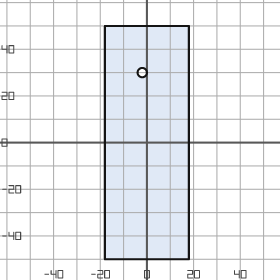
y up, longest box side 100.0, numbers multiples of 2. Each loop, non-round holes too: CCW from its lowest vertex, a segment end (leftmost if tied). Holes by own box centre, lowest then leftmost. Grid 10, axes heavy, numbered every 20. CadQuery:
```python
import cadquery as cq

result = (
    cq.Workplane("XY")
    .moveTo(-18.0, -50.0)
    .lineTo(18.0, -50.0)
    .lineTo(18.0, 50.0)
    .lineTo(-18.0, 50.0)
    .close()
    .moveTo(-2.0, 30.0)
    .circle(2.0)
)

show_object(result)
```